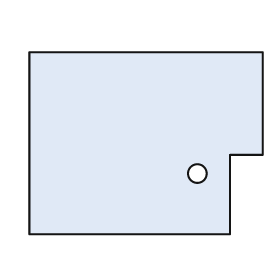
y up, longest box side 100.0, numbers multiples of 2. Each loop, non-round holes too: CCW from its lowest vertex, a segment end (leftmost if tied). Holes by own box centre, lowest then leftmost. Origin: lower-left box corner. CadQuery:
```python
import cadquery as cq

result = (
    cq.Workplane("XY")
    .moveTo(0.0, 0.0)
    .lineTo(86.0, 0.0)
    .lineTo(86.0, 34.0)
    .lineTo(100.0, 34.0)
    .lineTo(100.0, 78.0)
    .lineTo(0.0, 78.0)
    .close()
    .moveTo(72.0, 26.0)
    .circle(4.0)
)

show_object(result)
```